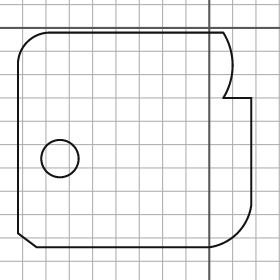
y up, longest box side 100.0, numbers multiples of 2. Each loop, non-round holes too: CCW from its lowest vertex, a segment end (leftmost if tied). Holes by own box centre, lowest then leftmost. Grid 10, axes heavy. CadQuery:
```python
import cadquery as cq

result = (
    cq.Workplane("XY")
    .moveTo(-74.0, -94.0)
    .lineTo(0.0, -94.0)
    .threePointArc((12.0, -88.0), (18.0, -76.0))
    .lineTo(18.0, -30.0)
    .lineTo(6.0, -30.0)
    .threePointArc((10.0, -16.0), (6.0, -2.0))
    .lineTo(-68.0, -2.0)
    .threePointArc((-78.0, -6.0), (-82.0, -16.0))
    .lineTo(-82.0, -88.0)
    .close()
    .moveTo(-64.0, -56.0)
    .circle(8.0)
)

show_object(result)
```